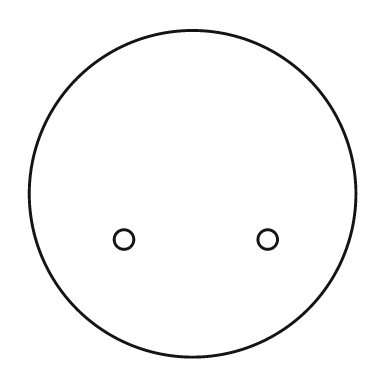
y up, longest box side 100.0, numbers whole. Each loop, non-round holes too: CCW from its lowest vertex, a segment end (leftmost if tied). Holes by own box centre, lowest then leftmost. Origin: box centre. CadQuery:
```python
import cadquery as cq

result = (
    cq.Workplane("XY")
    .moveTo(0.0, 0.0)
    .circle(50.0)
    .moveTo(-21.0, -14.0)
    .circle(3.0)
    .moveTo(23.0, -14.0)
    .circle(3.0)
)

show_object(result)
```